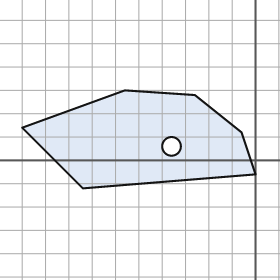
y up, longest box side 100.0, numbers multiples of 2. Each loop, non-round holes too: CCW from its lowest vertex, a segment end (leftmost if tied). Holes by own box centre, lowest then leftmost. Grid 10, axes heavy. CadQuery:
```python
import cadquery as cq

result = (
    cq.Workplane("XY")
    .moveTo(-74.0, -12.0)
    .lineTo(0.0, -6.0)
    .lineTo(-6.0, 12.0)
    .lineTo(-26.0, 28.0)
    .lineTo(-56.0, 30.0)
    .lineTo(-100.0, 14.0)
    .close()
    .moveTo(-36.0, 6.0)
    .circle(4.0)
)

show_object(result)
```